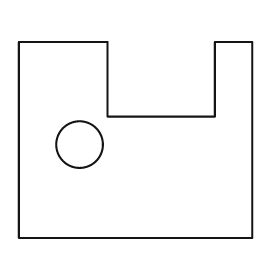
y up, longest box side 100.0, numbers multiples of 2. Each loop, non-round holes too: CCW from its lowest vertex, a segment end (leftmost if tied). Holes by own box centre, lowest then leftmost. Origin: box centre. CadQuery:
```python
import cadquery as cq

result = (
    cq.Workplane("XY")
    .moveTo(-50.0, -42.0)
    .lineTo(50.0, -42.0)
    .lineTo(50.0, 42.0)
    .lineTo(34.0, 42.0)
    .lineTo(34.0, 10.0)
    .lineTo(-12.0, 10.0)
    .lineTo(-12.0, 42.0)
    .lineTo(-50.0, 42.0)
    .close()
    .moveTo(-24.0, -2.0)
    .circle(10.0)
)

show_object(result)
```